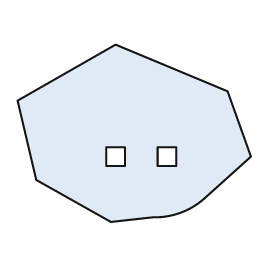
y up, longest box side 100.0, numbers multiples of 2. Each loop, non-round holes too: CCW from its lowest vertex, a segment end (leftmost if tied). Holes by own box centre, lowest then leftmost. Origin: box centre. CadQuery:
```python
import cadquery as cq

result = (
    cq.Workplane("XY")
    .moveTo(-10.0, -38.0)
    .lineTo(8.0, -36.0)
    .threePointArc((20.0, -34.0), (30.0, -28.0))
    .lineTo(50.0, -10.0)
    .lineTo(40.0, 18.0)
    .lineTo(-8.0, 38.0)
    .lineTo(-50.0, 14.0)
    .lineTo(-42.0, -20.0)
    .close()
    .moveTo(-12.0, -14.0)
    .lineTo(-4.0, -14.0)
    .lineTo(-4.0, -6.0)
    .lineTo(-12.0, -6.0)
    .close()
    .moveTo(10.0, -14.0)
    .lineTo(18.0, -14.0)
    .lineTo(18.0, -6.0)
    .lineTo(10.0, -6.0)
    .close()
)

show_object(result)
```